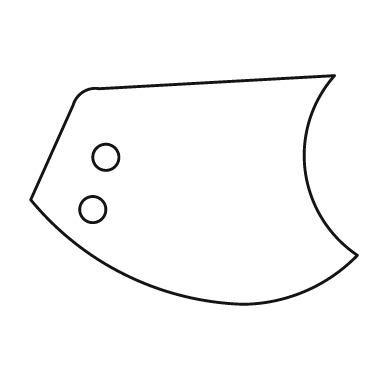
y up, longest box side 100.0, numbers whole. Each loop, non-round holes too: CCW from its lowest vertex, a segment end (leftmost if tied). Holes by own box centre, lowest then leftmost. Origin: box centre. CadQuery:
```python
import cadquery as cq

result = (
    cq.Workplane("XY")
    .moveTo(15.0, -35.0)
    .threePointArc((34.0, -31.0), (50.0, -20.0))
    .threePointArc((34.0, 6.0), (43.0, 35.0))
    .lineTo(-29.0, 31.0)
    .threePointArc((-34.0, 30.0), (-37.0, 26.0))
    .lineTo(-50.0, -3.0)
    .threePointArc((-21.0, -26.0), (15.0, -35.0))
    .close()
    .moveTo(-31.0, -6.0)
    .circle(4.0)
    .moveTo(-27.0, 10.0)
    .circle(4.0)
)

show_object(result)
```